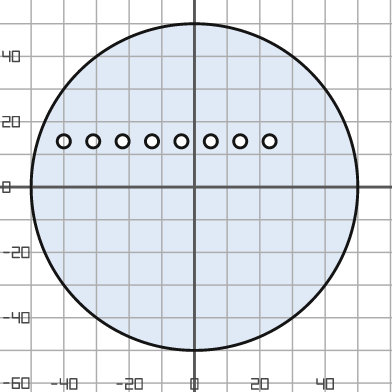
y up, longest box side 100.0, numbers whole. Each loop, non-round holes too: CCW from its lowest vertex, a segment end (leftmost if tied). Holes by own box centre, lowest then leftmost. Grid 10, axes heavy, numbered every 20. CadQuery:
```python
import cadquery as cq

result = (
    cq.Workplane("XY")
    .moveTo(0.0, 0.0)
    .circle(50.0)
    .moveTo(-40.0, 14.0)
    .circle(2.0)
    .moveTo(-31.0, 14.0)
    .circle(2.0)
    .moveTo(-22.0, 14.0)
    .circle(2.0)
    .moveTo(-13.0, 14.0)
    .circle(2.0)
    .moveTo(-4.0, 14.0)
    .circle(2.0)
    .moveTo(5.0, 14.0)
    .circle(2.0)
    .moveTo(14.0, 14.0)
    .circle(2.0)
    .moveTo(23.0, 14.0)
    .circle(2.0)
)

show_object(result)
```